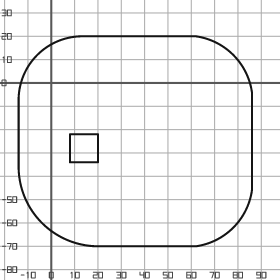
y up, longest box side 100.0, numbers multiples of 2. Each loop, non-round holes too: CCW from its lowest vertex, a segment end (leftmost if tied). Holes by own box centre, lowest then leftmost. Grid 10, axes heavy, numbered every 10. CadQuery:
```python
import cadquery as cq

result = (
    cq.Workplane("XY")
    .moveTo(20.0, -70.0)
    .lineTo(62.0, -70.0)
    .threePointArc((78.0, -62.0), (86.0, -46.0))
    .lineTo(86.0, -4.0)
    .threePointArc((78.0, 12.0), (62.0, 20.0))
    .lineTo(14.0, 20.0)
    .threePointArc((-6.0, 12.0), (-14.0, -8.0))
    .lineTo(-14.0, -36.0)
    .threePointArc((-4.0, -60.0), (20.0, -70.0))
    .close()
    .moveTo(8.0, -34.0)
    .lineTo(20.0, -34.0)
    .lineTo(20.0, -22.0)
    .lineTo(8.0, -22.0)
    .close()
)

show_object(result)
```